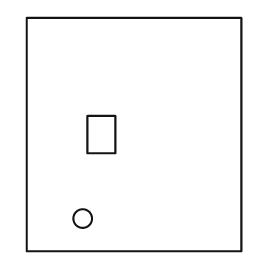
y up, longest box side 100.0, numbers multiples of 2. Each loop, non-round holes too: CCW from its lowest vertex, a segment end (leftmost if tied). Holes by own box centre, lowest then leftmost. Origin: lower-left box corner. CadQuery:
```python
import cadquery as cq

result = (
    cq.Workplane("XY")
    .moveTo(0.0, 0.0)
    .lineTo(92.0, 0.0)
    .lineTo(92.0, 100.0)
    .lineTo(0.0, 100.0)
    .close()
    .moveTo(24.0, 14.0)
    .circle(4.0)
    .moveTo(26.0, 42.0)
    .lineTo(38.0, 42.0)
    .lineTo(38.0, 58.0)
    .lineTo(26.0, 58.0)
    .close()
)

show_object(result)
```